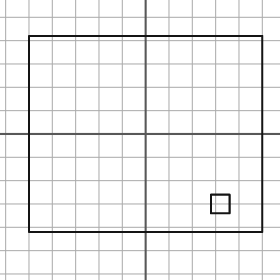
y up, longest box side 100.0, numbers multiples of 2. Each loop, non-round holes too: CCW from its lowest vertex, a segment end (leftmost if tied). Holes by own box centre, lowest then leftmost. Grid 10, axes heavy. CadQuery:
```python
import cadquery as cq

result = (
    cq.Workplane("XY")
    .moveTo(-50.0, -42.0)
    .lineTo(50.0, -42.0)
    .lineTo(50.0, 42.0)
    .lineTo(-50.0, 42.0)
    .close()
    .moveTo(28.0, -34.0)
    .lineTo(36.0, -34.0)
    .lineTo(36.0, -26.0)
    .lineTo(28.0, -26.0)
    .close()
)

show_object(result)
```